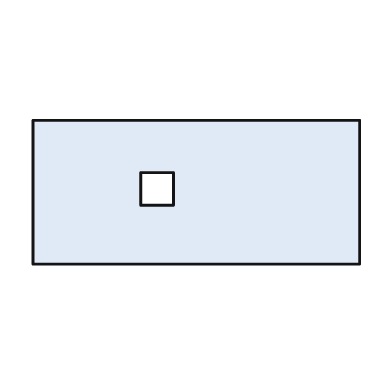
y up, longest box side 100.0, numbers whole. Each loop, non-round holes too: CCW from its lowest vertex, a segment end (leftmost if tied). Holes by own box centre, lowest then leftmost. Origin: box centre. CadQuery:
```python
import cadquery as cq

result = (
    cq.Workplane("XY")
    .moveTo(-50.0, -22.0)
    .lineTo(50.0, -22.0)
    .lineTo(50.0, 22.0)
    .lineTo(-50.0, 22.0)
    .close()
    .moveTo(-17.0, -4.0)
    .lineTo(-7.0, -4.0)
    .lineTo(-7.0, 6.0)
    .lineTo(-17.0, 6.0)
    .close()
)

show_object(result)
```